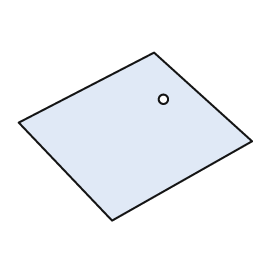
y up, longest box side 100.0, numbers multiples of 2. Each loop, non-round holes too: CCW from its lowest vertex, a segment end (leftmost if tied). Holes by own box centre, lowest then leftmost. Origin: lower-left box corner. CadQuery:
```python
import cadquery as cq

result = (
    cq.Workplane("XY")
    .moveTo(40.0, 0.0)
    .lineTo(100.0, 34.0)
    .lineTo(58.0, 72.0)
    .lineTo(0.0, 42.0)
    .close()
    .moveTo(62.0, 52.0)
    .circle(2.0)
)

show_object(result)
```